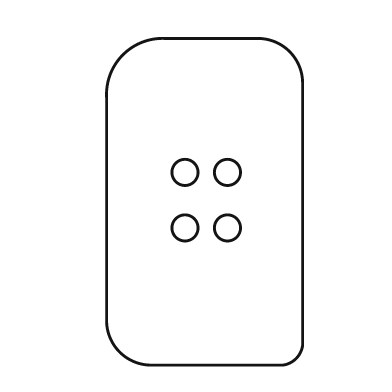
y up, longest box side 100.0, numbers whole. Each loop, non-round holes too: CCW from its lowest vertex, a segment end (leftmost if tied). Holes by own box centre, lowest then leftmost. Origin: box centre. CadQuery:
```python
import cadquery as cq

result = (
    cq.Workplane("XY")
    .moveTo(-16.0, -50.0)
    .lineTo(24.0, -50.0)
    .threePointArc((28.0, -48.0), (30.0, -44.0))
    .lineTo(30.0, 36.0)
    .threePointArc((26.0, 46.0), (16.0, 50.0))
    .lineTo(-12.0, 50.0)
    .threePointArc((-25.0, 45.0), (-30.0, 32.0))
    .lineTo(-30.0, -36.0)
    .threePointArc((-26.0, -46.0), (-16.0, -50.0))
    .close()
    .moveTo(-6.0, -8.0)
    .circle(4.0)
    .moveTo(7.0, -8.0)
    .circle(4.0)
    .moveTo(-6.0, 9.0)
    .circle(4.0)
    .moveTo(7.0, 9.0)
    .circle(4.0)
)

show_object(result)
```